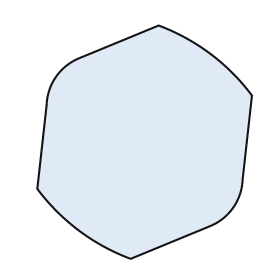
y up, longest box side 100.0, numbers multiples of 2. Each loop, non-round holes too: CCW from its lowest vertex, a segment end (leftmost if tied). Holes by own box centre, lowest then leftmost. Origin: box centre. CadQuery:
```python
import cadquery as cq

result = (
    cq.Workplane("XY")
    .moveTo(-6.0, -50.0)
    .lineTo(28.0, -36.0)
    .threePointArc((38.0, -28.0), (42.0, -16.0))
    .lineTo(46.0, 20.0)
    .threePointArc((28.0, 38.0), (6.0, 50.0))
    .lineTo(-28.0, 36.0)
    .threePointArc((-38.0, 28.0), (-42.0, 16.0))
    .lineTo(-46.0, -20.0)
    .threePointArc((-28.0, -38.0), (-6.0, -50.0))
    .close()
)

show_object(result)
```